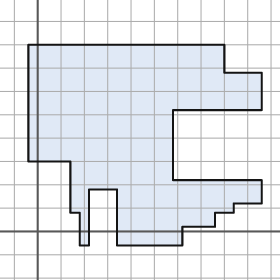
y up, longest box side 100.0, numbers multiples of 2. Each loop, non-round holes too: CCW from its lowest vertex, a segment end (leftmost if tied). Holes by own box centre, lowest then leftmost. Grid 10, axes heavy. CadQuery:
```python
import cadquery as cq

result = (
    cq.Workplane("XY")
    .moveTo(18.0, -6.0)
    .lineTo(22.0, -6.0)
    .lineTo(22.0, 18.0)
    .lineTo(34.0, 18.0)
    .lineTo(34.0, -6.0)
    .lineTo(62.0, -6.0)
    .lineTo(62.0, 2.0)
    .lineTo(76.0, 2.0)
    .lineTo(76.0, 8.0)
    .lineTo(84.0, 8.0)
    .lineTo(84.0, 12.0)
    .lineTo(96.0, 12.0)
    .lineTo(96.0, 22.0)
    .lineTo(58.0, 22.0)
    .lineTo(58.0, 52.0)
    .lineTo(96.0, 52.0)
    .lineTo(96.0, 68.0)
    .lineTo(80.0, 68.0)
    .lineTo(80.0, 80.0)
    .lineTo(-4.0, 80.0)
    .lineTo(-4.0, 30.0)
    .lineTo(14.0, 30.0)
    .lineTo(14.0, 8.0)
    .lineTo(18.0, 8.0)
    .close()
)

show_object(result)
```